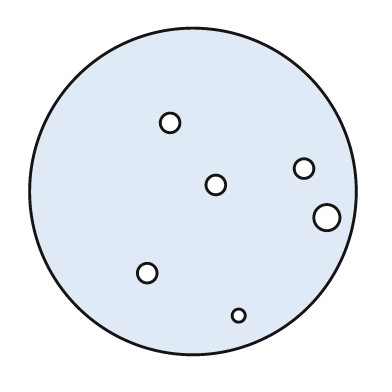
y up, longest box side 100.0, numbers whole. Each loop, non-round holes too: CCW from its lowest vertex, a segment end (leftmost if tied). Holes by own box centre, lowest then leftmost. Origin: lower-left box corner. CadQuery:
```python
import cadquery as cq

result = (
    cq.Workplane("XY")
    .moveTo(50.0, 50.0)
    .circle(50.0)
    .moveTo(64.0, 12.0)
    .circle(2.0)
    .moveTo(36.0, 25.0)
    .circle(3.0)
    .moveTo(91.0, 42.0)
    .circle(4.0)
    .moveTo(57.0, 52.0)
    .circle(3.0)
    .moveTo(84.0, 57.0)
    .circle(3.0)
    .moveTo(43.0, 71.0)
    .circle(3.0)
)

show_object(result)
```